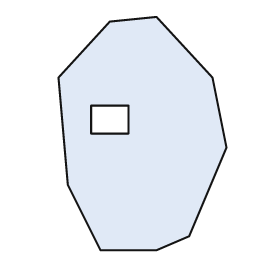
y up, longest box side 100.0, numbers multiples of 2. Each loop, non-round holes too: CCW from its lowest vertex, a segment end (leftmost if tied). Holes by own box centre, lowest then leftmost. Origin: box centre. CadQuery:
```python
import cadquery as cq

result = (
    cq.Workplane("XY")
    .moveTo(-18.0, -50.0)
    .lineTo(6.0, -50.0)
    .lineTo(20.0, -44.0)
    .lineTo(36.0, -6.0)
    .lineTo(30.0, 24.0)
    .lineTo(6.0, 50.0)
    .lineTo(-14.0, 48.0)
    .lineTo(-36.0, 24.0)
    .lineTo(-32.0, -22.0)
    .close()
    .moveTo(-22.0, 0.0)
    .lineTo(-6.0, 0.0)
    .lineTo(-6.0, 12.0)
    .lineTo(-22.0, 12.0)
    .close()
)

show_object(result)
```